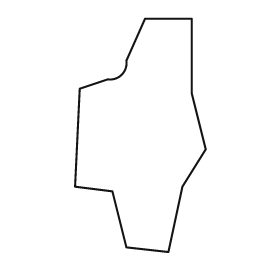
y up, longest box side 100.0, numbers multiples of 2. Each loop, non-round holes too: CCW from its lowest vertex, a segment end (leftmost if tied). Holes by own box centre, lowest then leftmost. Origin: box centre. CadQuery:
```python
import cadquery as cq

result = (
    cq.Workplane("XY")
    .moveTo(12.0, -50.0)
    .lineTo(18.0, -22.0)
    .lineTo(28.0, -6.0)
    .lineTo(22.0, 18.0)
    .lineTo(22.0, 50.0)
    .lineTo(2.0, 50.0)
    .lineTo(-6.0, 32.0)
    .threePointArc((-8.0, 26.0), (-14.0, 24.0))
    .lineTo(-26.0, 20.0)
    .lineTo(-28.0, -22.0)
    .lineTo(-12.0, -24.0)
    .lineTo(-6.0, -48.0)
    .close()
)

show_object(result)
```